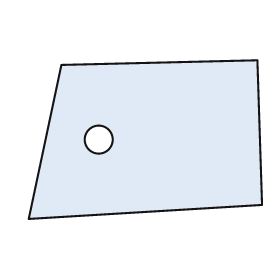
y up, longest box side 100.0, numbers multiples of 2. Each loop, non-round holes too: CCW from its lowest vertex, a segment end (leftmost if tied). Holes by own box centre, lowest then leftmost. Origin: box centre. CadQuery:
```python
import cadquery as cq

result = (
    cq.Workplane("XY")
    .moveTo(-50.0, -34.0)
    .lineTo(50.0, -28.0)
    .lineTo(48.0, 34.0)
    .lineTo(-36.0, 32.0)
    .close()
    .moveTo(-20.0, 0.0)
    .circle(6.0)
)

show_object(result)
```